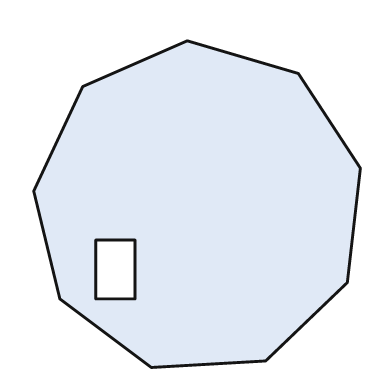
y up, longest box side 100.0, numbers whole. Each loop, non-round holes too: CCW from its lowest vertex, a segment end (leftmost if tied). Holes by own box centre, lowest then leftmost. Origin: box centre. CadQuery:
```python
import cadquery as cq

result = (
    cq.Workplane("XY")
    .moveTo(-14.0, -50.0)
    .lineTo(21.0, -48.0)
    .lineTo(46.0, -24.0)
    .lineTo(50.0, 11.0)
    .lineTo(31.0, 40.0)
    .lineTo(-3.0, 50.0)
    .lineTo(-35.0, 36.0)
    .lineTo(-50.0, 4.0)
    .lineTo(-42.0, -29.0)
    .close()
    .moveTo(-31.0, -29.0)
    .lineTo(-19.0, -29.0)
    .lineTo(-19.0, -11.0)
    .lineTo(-31.0, -11.0)
    .close()
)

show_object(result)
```